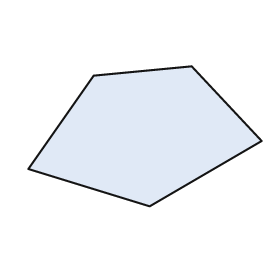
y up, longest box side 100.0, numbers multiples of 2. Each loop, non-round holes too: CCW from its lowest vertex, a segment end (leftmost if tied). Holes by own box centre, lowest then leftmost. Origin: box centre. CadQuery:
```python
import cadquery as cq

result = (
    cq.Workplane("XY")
    .moveTo(2.0, -30.0)
    .lineTo(50.0, -2.0)
    .lineTo(20.0, 30.0)
    .lineTo(-22.0, 26.0)
    .lineTo(-50.0, -14.0)
    .close()
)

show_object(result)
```